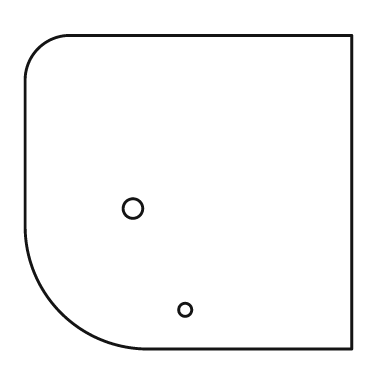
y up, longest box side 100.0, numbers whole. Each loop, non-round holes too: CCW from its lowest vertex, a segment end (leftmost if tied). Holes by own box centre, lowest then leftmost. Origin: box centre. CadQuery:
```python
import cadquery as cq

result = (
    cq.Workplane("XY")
    .moveTo(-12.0, -48.0)
    .lineTo(50.0, -48.0)
    .lineTo(50.0, 48.0)
    .lineTo(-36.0, 48.0)
    .threePointArc((-46.0, 44.0), (-50.0, 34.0))
    .lineTo(-50.0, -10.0)
    .threePointArc((-39.0, -37.0), (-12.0, -48.0))
    .close()
    .moveTo(-1.0, -36.0)
    .circle(2.0)
    .moveTo(-17.0, -5.0)
    .circle(3.0)
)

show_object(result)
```